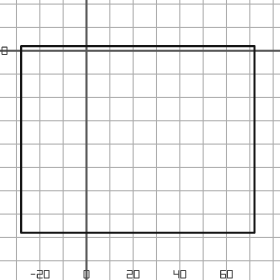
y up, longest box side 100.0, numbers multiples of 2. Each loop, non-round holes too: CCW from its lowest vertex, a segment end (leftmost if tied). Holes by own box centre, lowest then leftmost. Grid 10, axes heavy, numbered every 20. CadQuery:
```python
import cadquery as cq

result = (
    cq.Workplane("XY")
    .moveTo(-28.0, -78.0)
    .lineTo(72.0, -78.0)
    .lineTo(72.0, 2.0)
    .lineTo(-28.0, 2.0)
    .close()
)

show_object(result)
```